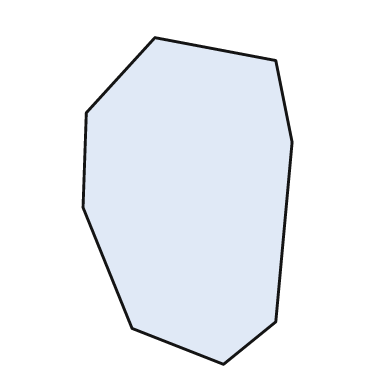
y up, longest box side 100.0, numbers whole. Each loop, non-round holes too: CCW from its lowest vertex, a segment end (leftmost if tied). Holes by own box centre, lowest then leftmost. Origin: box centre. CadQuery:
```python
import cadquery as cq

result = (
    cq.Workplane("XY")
    .moveTo(11.0, -50.0)
    .lineTo(27.0, -37.0)
    .lineTo(32.0, 18.0)
    .lineTo(27.0, 43.0)
    .lineTo(-10.0, 50.0)
    .lineTo(-31.0, 27.0)
    .lineTo(-32.0, -2.0)
    .lineTo(-17.0, -39.0)
    .close()
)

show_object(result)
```